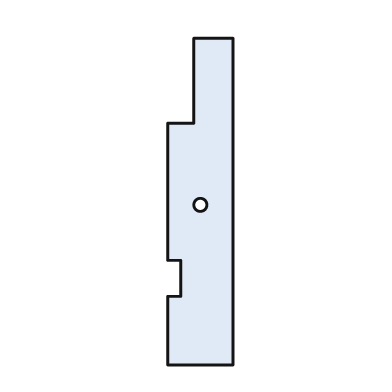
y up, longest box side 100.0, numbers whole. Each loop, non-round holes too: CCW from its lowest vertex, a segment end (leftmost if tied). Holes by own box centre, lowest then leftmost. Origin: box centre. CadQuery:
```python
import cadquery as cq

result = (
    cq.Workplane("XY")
    .moveTo(-10.0, -50.0)
    .lineTo(10.0, -50.0)
    .lineTo(10.0, 50.0)
    .lineTo(-2.0, 50.0)
    .lineTo(-2.0, 24.0)
    .lineTo(-10.0, 24.0)
    .lineTo(-10.0, -18.0)
    .lineTo(-6.0, -18.0)
    .lineTo(-6.0, -29.0)
    .lineTo(-10.0, -29.0)
    .close()
    .moveTo(0.0, -1.0)
    .circle(2.0)
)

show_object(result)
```